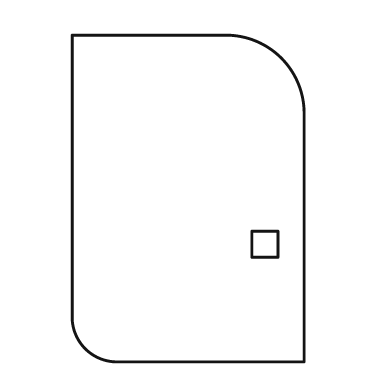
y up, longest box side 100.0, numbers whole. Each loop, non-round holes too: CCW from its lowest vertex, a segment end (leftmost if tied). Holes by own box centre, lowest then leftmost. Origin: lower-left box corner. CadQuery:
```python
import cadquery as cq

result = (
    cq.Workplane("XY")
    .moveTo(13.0, 0.0)
    .lineTo(71.0, 0.0)
    .lineTo(71.0, 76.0)
    .threePointArc((64.0, 93.0), (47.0, 100.0))
    .lineTo(0.0, 100.0)
    .lineTo(0.0, 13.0)
    .threePointArc((4.0, 4.0), (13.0, 0.0))
    .close()
    .moveTo(55.0, 32.0)
    .lineTo(63.0, 32.0)
    .lineTo(63.0, 40.0)
    .lineTo(55.0, 40.0)
    .close()
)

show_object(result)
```